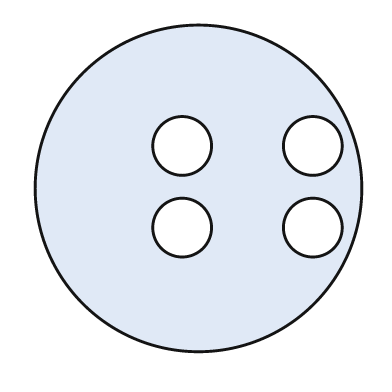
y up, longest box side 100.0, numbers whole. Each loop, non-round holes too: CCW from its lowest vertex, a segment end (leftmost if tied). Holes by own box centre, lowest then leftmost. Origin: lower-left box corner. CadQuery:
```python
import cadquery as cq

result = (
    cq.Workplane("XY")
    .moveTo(50.0, 50.0)
    .circle(50.0)
    .moveTo(45.0, 38.0)
    .circle(9.0)
    .moveTo(85.0, 38.0)
    .circle(9.0)
    .moveTo(45.0, 63.0)
    .circle(9.0)
    .moveTo(85.0, 63.0)
    .circle(9.0)
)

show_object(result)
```